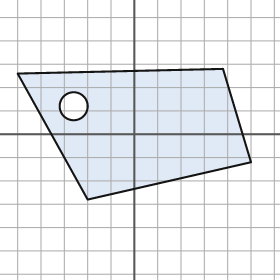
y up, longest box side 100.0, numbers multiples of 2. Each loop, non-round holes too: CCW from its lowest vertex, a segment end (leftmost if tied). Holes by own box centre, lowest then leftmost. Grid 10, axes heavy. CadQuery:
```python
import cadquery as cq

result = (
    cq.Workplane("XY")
    .moveTo(-20.0, -28.0)
    .lineTo(50.0, -12.0)
    .lineTo(38.0, 28.0)
    .lineTo(-50.0, 26.0)
    .close()
    .moveTo(-26.0, 12.0)
    .circle(6.0)
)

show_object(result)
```